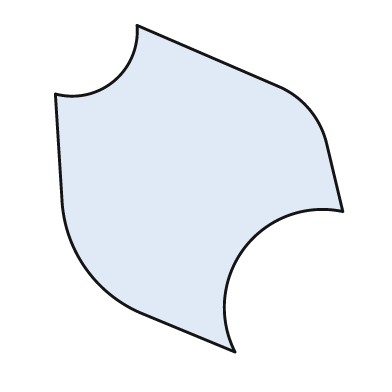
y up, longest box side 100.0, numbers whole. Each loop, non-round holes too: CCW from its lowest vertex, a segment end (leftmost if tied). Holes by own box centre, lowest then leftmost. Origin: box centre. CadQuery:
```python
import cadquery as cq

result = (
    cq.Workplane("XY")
    .moveTo(11.0, -50.0)
    .threePointArc((14.0, -18.0), (44.0, -7.0))
    .lineTo(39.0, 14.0)
    .threePointArc((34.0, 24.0), (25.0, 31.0))
    .lineTo(-19.0, 50.0)
    .threePointArc((-26.0, 33.0), (-44.0, 29.0))
    .lineTo(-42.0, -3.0)
    .threePointArc((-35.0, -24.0), (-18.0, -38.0))
    .close()
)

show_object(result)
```